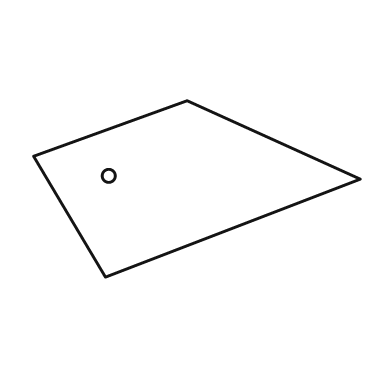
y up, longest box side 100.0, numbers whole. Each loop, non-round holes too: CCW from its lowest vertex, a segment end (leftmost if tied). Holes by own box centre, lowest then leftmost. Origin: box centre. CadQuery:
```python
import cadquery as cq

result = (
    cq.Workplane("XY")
    .moveTo(-28.0, -27.0)
    .lineTo(50.0, 3.0)
    .lineTo(-3.0, 27.0)
    .lineTo(-50.0, 10.0)
    .close()
    .moveTo(-27.0, 4.0)
    .circle(2.0)
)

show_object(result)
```